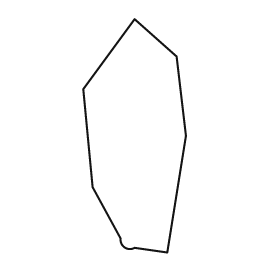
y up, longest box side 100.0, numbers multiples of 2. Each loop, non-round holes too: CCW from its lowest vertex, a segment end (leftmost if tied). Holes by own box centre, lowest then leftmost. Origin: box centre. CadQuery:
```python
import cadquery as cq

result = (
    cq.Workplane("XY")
    .moveTo(14.0, -50.0)
    .lineTo(22.0, 0.0)
    .lineTo(18.0, 34.0)
    .lineTo(0.0, 50.0)
    .lineTo(-22.0, 20.0)
    .lineTo(-18.0, -22.0)
    .lineTo(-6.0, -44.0)
    .threePointArc((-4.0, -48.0), (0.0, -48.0))
    .close()
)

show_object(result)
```